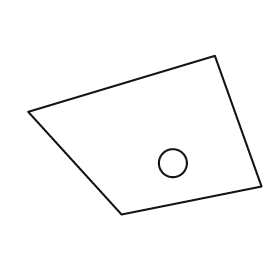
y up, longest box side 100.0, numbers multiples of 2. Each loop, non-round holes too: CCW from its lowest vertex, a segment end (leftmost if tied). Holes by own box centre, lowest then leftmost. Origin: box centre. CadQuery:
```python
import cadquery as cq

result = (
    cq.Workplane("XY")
    .moveTo(-10.0, -34.0)
    .lineTo(50.0, -22.0)
    .lineTo(30.0, 34.0)
    .lineTo(-50.0, 10.0)
    .close()
    .moveTo(12.0, -12.0)
    .circle(6.0)
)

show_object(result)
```